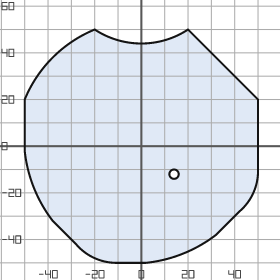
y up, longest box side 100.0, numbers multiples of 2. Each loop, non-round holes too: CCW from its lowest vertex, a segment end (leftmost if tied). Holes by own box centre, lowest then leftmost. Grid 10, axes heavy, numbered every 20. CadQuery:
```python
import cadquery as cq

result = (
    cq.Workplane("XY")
    .moveTo(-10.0, -50.0)
    .lineTo(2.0, -50.0)
    .threePointArc((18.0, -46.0), (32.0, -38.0))
    .lineTo(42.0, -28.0)
    .threePointArc((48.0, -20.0), (50.0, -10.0))
    .lineTo(50.0, 20.0)
    .lineTo(20.0, 50.0)
    .threePointArc((0.0, 44.0), (-20.0, 50.0))
    .threePointArc((-38.0, 38.0), (-50.0, 20.0))
    .lineTo(-50.0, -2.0)
    .threePointArc((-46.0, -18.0), (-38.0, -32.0))
    .lineTo(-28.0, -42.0)
    .threePointArc((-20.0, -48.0), (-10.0, -50.0))
    .close()
    .moveTo(14.0, -12.0)
    .circle(2.0)
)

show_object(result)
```